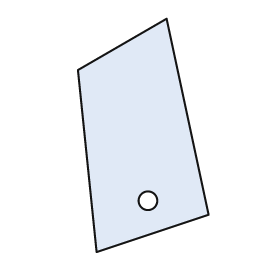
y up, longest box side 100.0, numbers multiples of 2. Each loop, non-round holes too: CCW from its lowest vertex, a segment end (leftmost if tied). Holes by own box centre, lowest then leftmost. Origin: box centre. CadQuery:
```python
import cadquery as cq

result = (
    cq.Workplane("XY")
    .moveTo(-20.0, -50.0)
    .lineTo(28.0, -34.0)
    .lineTo(10.0, 50.0)
    .lineTo(-28.0, 28.0)
    .close()
    .moveTo(2.0, -28.0)
    .circle(4.0)
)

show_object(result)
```